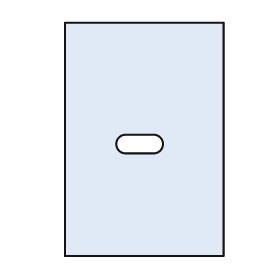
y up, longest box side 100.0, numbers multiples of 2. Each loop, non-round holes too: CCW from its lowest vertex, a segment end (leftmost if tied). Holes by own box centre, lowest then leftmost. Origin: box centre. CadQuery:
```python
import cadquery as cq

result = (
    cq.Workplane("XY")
    .moveTo(-34.0, -50.0)
    .lineTo(34.0, -50.0)
    .lineTo(34.0, 50.0)
    .lineTo(-34.0, 50.0)
    .close()
    .moveTo(-8.0, -6.0)
    .lineTo(4.0, -6.0)
    .threePointArc((8.0, -2.0), (4.0, 2.0))
    .lineTo(-8.0, 2.0)
    .threePointArc((-12.0, -2.0), (-8.0, -6.0))
    .close()
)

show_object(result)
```